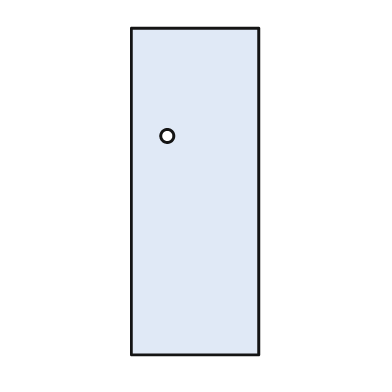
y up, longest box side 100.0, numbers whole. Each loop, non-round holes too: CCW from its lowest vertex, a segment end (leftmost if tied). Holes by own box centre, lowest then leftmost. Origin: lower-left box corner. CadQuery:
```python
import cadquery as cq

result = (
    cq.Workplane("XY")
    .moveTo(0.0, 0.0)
    .lineTo(39.0, 0.0)
    .lineTo(39.0, 100.0)
    .lineTo(0.0, 100.0)
    .close()
    .moveTo(11.0, 67.0)
    .circle(2.0)
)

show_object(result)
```